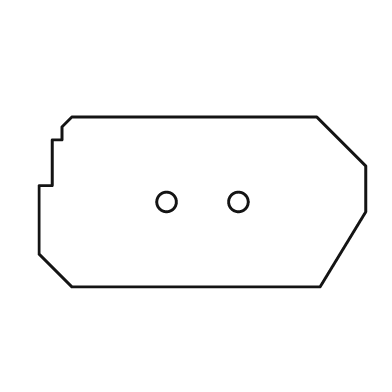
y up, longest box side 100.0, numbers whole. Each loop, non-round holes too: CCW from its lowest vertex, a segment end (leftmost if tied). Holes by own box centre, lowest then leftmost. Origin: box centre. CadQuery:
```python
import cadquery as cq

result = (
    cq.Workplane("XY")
    .moveTo(-40.0, -26.0)
    .lineTo(36.0, -26.0)
    .lineTo(50.0, -3.0)
    .lineTo(50.0, 11.0)
    .lineTo(35.0, 26.0)
    .lineTo(-40.0, 26.0)
    .lineTo(-43.0, 23.0)
    .lineTo(-43.0, 19.0)
    .lineTo(-46.0, 19.0)
    .lineTo(-46.0, 5.0)
    .lineTo(-50.0, 5.0)
    .lineTo(-50.0, -16.0)
    .close()
    .moveTo(-11.0, 0.0)
    .circle(3.0)
    .moveTo(11.0, 0.0)
    .circle(3.0)
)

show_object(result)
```